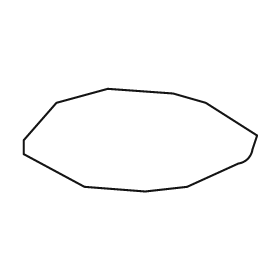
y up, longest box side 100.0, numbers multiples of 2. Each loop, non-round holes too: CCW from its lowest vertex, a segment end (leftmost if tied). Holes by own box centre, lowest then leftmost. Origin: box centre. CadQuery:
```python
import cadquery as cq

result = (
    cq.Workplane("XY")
    .moveTo(2.0, -22.0)
    .lineTo(20.0, -20.0)
    .lineTo(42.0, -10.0)
    .threePointArc((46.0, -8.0), (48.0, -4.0))
    .lineTo(50.0, 2.0)
    .lineTo(28.0, 16.0)
    .lineTo(14.0, 20.0)
    .lineTo(-14.0, 22.0)
    .lineTo(-36.0, 16.0)
    .lineTo(-50.0, 0.0)
    .lineTo(-50.0, -6.0)
    .lineTo(-24.0, -20.0)
    .close()
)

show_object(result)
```